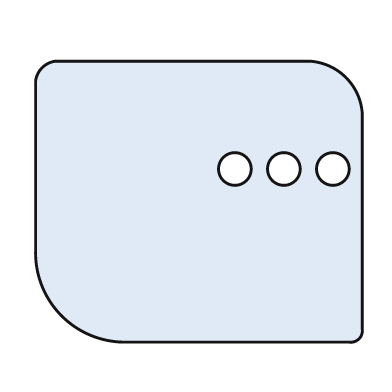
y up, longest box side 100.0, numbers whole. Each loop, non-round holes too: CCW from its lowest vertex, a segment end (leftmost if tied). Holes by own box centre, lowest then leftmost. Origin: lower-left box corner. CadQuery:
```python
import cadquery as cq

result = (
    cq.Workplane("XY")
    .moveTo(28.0, 0.0)
    .lineTo(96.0, 0.0)
    .threePointArc((99.0, 1.0), (100.0, 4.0))
    .lineTo(100.0, 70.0)
    .threePointArc((95.0, 81.0), (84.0, 86.0))
    .lineTo(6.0, 86.0)
    .threePointArc((2.0, 84.0), (0.0, 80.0))
    .lineTo(0.0, 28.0)
    .threePointArc((8.0, 8.0), (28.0, 0.0))
    .close()
    .moveTo(61.0, 53.0)
    .circle(5.0)
    .moveTo(76.0, 53.0)
    .circle(5.0)
    .moveTo(91.0, 53.0)
    .circle(5.0)
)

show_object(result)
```